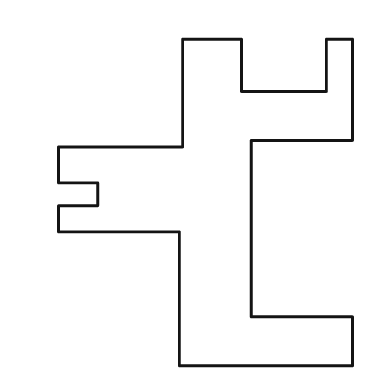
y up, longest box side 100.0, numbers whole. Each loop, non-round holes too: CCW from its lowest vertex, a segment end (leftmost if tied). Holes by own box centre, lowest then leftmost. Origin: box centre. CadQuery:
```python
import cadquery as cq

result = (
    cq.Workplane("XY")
    .moveTo(-8.0, -50.0)
    .lineTo(45.0, -50.0)
    .lineTo(45.0, -35.0)
    .lineTo(14.0, -35.0)
    .lineTo(14.0, 19.0)
    .lineTo(45.0, 19.0)
    .lineTo(45.0, 50.0)
    .lineTo(37.0, 50.0)
    .lineTo(37.0, 34.0)
    .lineTo(11.0, 34.0)
    .lineTo(11.0, 50.0)
    .lineTo(-7.0, 50.0)
    .lineTo(-7.0, 17.0)
    .lineTo(-45.0, 17.0)
    .lineTo(-45.0, 6.0)
    .lineTo(-33.0, 6.0)
    .lineTo(-33.0, -1.0)
    .lineTo(-45.0, -1.0)
    .lineTo(-45.0, -9.0)
    .lineTo(-8.0, -9.0)
    .close()
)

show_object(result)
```